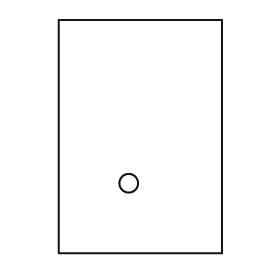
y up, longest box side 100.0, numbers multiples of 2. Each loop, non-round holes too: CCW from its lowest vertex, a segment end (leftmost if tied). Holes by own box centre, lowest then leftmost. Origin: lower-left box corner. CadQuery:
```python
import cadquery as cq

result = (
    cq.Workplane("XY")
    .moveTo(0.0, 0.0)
    .lineTo(70.0, 0.0)
    .lineTo(70.0, 100.0)
    .lineTo(0.0, 100.0)
    .close()
    .moveTo(30.0, 30.0)
    .circle(4.0)
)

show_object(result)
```